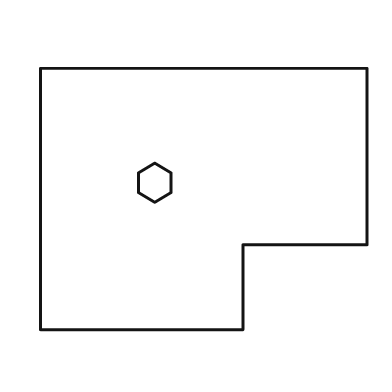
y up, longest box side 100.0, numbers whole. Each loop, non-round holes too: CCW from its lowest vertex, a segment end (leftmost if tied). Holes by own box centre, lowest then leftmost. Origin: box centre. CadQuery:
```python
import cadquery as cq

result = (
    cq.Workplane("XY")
    .moveTo(-50.0, -40.0)
    .lineTo(12.0, -40.0)
    .lineTo(12.0, -14.0)
    .lineTo(50.0, -14.0)
    .lineTo(50.0, 40.0)
    .lineTo(-50.0, 40.0)
    .close()
    .moveTo(-15.0, -1.0)
    .lineTo(-10.0, 2.0)
    .lineTo(-10.0, 8.0)
    .lineTo(-15.0, 11.0)
    .lineTo(-20.0, 8.0)
    .lineTo(-20.0, 2.0)
    .close()
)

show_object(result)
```